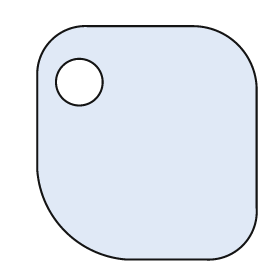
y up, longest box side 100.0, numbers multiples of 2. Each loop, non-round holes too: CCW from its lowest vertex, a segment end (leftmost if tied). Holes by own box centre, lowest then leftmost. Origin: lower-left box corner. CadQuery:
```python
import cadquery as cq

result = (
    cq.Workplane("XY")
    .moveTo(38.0, 0.0)
    .lineTo(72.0, 0.0)
    .threePointArc((88.0, 6.0), (94.0, 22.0))
    .lineTo(94.0, 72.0)
    .threePointArc((86.0, 92.0), (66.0, 100.0))
    .lineTo(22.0, 100.0)
    .threePointArc((6.0, 94.0), (0.0, 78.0))
    .lineTo(0.0, 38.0)
    .threePointArc((12.0, 12.0), (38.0, 0.0))
    .close()
    .moveTo(18.0, 76.0)
    .circle(10.0)
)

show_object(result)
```